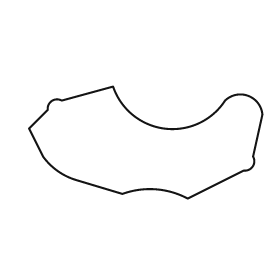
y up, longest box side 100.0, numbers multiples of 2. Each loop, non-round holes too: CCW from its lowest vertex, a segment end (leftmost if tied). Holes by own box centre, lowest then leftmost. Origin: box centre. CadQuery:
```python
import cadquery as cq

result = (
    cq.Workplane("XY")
    .moveTo(18.0, -24.0)
    .lineTo(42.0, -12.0)
    .threePointArc((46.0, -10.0), (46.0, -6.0))
    .lineTo(50.0, 12.0)
    .threePointArc((44.0, 20.0), (34.0, 18.0))
    .threePointArc((8.0, 6.0), (-14.0, 24.0))
    .lineTo(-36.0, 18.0)
    .threePointArc((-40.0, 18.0), (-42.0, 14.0))
    .lineTo(-50.0, 6.0)
    .lineTo(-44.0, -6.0)
    .threePointArc((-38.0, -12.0), (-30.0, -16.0))
    .lineTo(-10.0, -22.0)
    .threePointArc((4.0, -20.0), (18.0, -24.0))
    .close()
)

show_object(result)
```